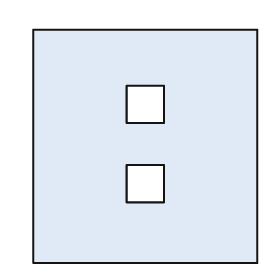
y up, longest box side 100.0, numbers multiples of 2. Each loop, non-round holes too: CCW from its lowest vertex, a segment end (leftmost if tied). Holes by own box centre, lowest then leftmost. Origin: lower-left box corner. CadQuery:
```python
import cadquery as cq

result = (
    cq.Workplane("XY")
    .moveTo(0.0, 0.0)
    .lineTo(96.0, 0.0)
    .lineTo(96.0, 100.0)
    .lineTo(0.0, 100.0)
    .close()
    .moveTo(40.0, 26.0)
    .lineTo(56.0, 26.0)
    .lineTo(56.0, 42.0)
    .lineTo(40.0, 42.0)
    .close()
    .moveTo(40.0, 60.0)
    .lineTo(56.0, 60.0)
    .lineTo(56.0, 76.0)
    .lineTo(40.0, 76.0)
    .close()
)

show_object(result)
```